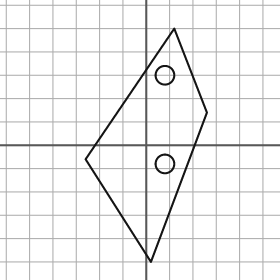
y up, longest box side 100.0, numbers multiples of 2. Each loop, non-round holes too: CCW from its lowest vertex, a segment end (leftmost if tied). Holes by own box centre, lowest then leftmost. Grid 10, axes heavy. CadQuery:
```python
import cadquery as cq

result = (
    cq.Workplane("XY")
    .moveTo(2.0, -50.0)
    .lineTo(26.0, 14.0)
    .lineTo(12.0, 50.0)
    .lineTo(-26.0, -6.0)
    .close()
    .moveTo(8.0, -8.0)
    .circle(4.0)
    .moveTo(8.0, 30.0)
    .circle(4.0)
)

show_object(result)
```